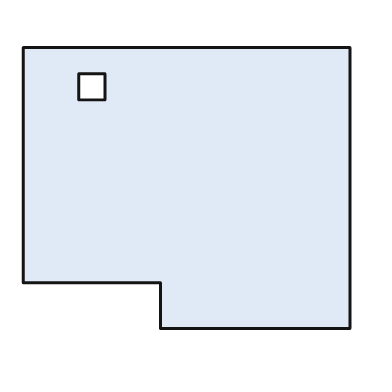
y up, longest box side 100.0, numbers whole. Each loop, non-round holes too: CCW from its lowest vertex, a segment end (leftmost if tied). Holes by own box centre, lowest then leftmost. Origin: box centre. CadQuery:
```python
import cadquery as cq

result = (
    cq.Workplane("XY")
    .moveTo(-8.0, -43.0)
    .lineTo(50.0, -43.0)
    .lineTo(50.0, 43.0)
    .lineTo(-50.0, 43.0)
    .lineTo(-50.0, -29.0)
    .lineTo(-8.0, -29.0)
    .close()
    .moveTo(-33.0, 27.0)
    .lineTo(-25.0, 27.0)
    .lineTo(-25.0, 35.0)
    .lineTo(-33.0, 35.0)
    .close()
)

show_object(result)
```